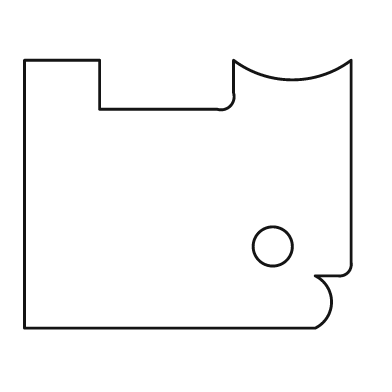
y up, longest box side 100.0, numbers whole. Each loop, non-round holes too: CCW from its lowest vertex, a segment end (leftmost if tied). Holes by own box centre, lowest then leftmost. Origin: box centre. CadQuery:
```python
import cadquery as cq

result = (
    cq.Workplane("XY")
    .moveTo(-50.0, -41.0)
    .lineTo(39.0, -41.0)
    .threePointArc((44.0, -33.0), (39.0, -25.0))
    .lineTo(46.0, -25.0)
    .threePointArc((49.0, -24.0), (50.0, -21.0))
    .lineTo(50.0, 41.0)
    .threePointArc((32.0, 35.0), (14.0, 41.0))
    .lineTo(14.0, 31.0)
    .threePointArc((13.0, 27.0), (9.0, 26.0))
    .lineTo(-27.0, 26.0)
    .lineTo(-27.0, 41.0)
    .lineTo(-50.0, 41.0)
    .close()
    .moveTo(26.0, -16.0)
    .circle(6.0)
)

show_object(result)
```